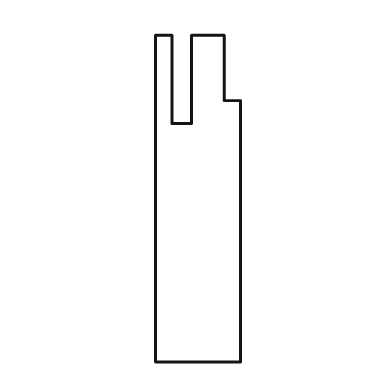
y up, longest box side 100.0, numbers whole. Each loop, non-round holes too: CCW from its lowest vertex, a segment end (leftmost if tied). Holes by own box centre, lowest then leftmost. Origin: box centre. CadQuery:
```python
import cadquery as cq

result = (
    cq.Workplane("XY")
    .moveTo(-13.0, -50.0)
    .lineTo(13.0, -50.0)
    .lineTo(13.0, 30.0)
    .lineTo(8.0, 30.0)
    .lineTo(8.0, 50.0)
    .lineTo(-2.0, 50.0)
    .lineTo(-2.0, 23.0)
    .lineTo(-8.0, 23.0)
    .lineTo(-8.0, 50.0)
    .lineTo(-13.0, 50.0)
    .close()
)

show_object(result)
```